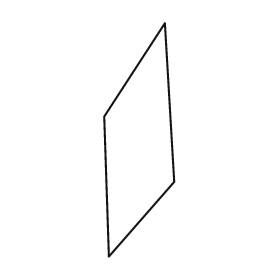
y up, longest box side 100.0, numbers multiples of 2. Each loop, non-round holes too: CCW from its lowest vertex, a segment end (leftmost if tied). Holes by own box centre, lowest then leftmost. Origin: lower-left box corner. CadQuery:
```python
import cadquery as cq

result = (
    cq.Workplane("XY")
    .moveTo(2.0, 0.0)
    .lineTo(30.0, 32.0)
    .lineTo(26.0, 100.0)
    .lineTo(0.0, 60.0)
    .close()
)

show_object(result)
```